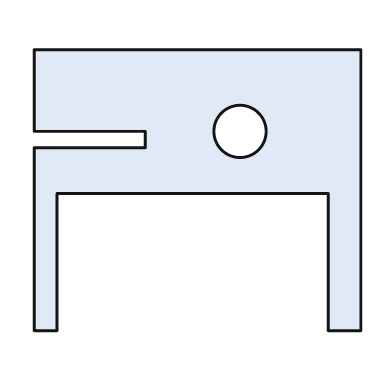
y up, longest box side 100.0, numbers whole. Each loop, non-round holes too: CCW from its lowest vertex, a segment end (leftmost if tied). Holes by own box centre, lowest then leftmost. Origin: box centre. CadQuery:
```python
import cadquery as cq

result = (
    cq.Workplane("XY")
    .moveTo(-50.0, -43.0)
    .lineTo(-43.0, -43.0)
    .lineTo(-43.0, -1.0)
    .lineTo(40.0, -1.0)
    .lineTo(40.0, -43.0)
    .lineTo(50.0, -43.0)
    .lineTo(50.0, 43.0)
    .lineTo(-50.0, 43.0)
    .lineTo(-50.0, 18.0)
    .lineTo(-16.0, 18.0)
    .lineTo(-16.0, 13.0)
    .lineTo(-50.0, 13.0)
    .close()
    .moveTo(13.0, 18.0)
    .circle(8.0)
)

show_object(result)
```